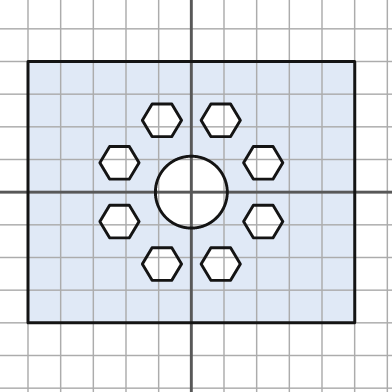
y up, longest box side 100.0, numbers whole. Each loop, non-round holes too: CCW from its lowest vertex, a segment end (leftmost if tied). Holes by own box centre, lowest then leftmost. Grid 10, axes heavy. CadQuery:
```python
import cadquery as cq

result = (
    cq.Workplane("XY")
    .moveTo(-50.0, -40.0)
    .lineTo(50.0, -40.0)
    .lineTo(50.0, 40.0)
    .lineTo(-50.0, 40.0)
    .close()
    .moveTo(-12.0, -27.0)
    .lineTo(-6.0, -27.0)
    .lineTo(-3.0, -22.0)
    .lineTo(-6.0, -17.0)
    .lineTo(-12.0, -17.0)
    .lineTo(-15.0, -22.0)
    .close()
    .moveTo(6.0, -27.0)
    .lineTo(12.0, -27.0)
    .lineTo(15.0, -22.0)
    .lineTo(12.0, -17.0)
    .lineTo(6.0, -17.0)
    .lineTo(3.0, -22.0)
    .close()
    .moveTo(-25.0, -14.0)
    .lineTo(-19.0, -14.0)
    .lineTo(-16.0, -9.0)
    .lineTo(-19.0, -4.0)
    .lineTo(-25.0, -4.0)
    .lineTo(-28.0, -9.0)
    .close()
    .moveTo(19.0, -14.0)
    .lineTo(25.0, -14.0)
    .lineTo(28.0, -9.0)
    .lineTo(25.0, -4.0)
    .lineTo(19.0, -4.0)
    .lineTo(16.0, -9.0)
    .close()
    .moveTo(0.0, 0.0)
    .circle(11.0)
    .moveTo(-25.0, 4.0)
    .lineTo(-19.0, 4.0)
    .lineTo(-16.0, 9.0)
    .lineTo(-19.0, 14.0)
    .lineTo(-25.0, 14.0)
    .lineTo(-28.0, 9.0)
    .close()
    .moveTo(19.0, 4.0)
    .lineTo(25.0, 4.0)
    .lineTo(28.0, 9.0)
    .lineTo(25.0, 14.0)
    .lineTo(19.0, 14.0)
    .lineTo(16.0, 9.0)
    .close()
    .moveTo(-12.0, 17.0)
    .lineTo(-6.0, 17.0)
    .lineTo(-3.0, 22.0)
    .lineTo(-6.0, 27.0)
    .lineTo(-12.0, 27.0)
    .lineTo(-15.0, 22.0)
    .close()
    .moveTo(6.0, 17.0)
    .lineTo(12.0, 17.0)
    .lineTo(15.0, 22.0)
    .lineTo(12.0, 27.0)
    .lineTo(6.0, 27.0)
    .lineTo(3.0, 22.0)
    .close()
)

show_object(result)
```